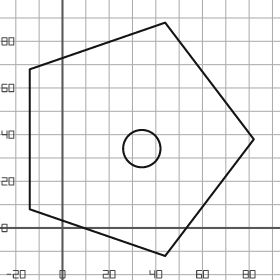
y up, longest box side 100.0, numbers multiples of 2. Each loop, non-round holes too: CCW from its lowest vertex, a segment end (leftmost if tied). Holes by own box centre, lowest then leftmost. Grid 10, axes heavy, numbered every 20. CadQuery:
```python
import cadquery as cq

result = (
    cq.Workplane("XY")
    .moveTo(44.0, -12.0)
    .lineTo(82.0, 38.0)
    .lineTo(44.0, 88.0)
    .lineTo(-14.0, 68.0)
    .lineTo(-14.0, 8.0)
    .close()
    .moveTo(34.0, 34.0)
    .circle(8.0)
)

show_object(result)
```